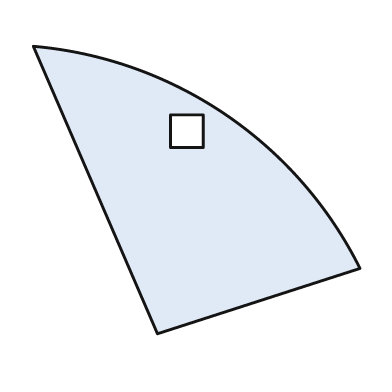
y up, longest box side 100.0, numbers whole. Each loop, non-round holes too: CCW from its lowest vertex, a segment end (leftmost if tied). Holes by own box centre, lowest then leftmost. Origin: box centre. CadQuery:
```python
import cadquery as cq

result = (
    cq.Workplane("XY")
    .moveTo(-12.0, -44.0)
    .lineTo(50.0, -24.0)
    .threePointArc((9.0, 23.0), (-50.0, 44.0))
    .close()
    .moveTo(-8.0, 13.0)
    .lineTo(2.0, 13.0)
    .lineTo(2.0, 23.0)
    .lineTo(-8.0, 23.0)
    .close()
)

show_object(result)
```